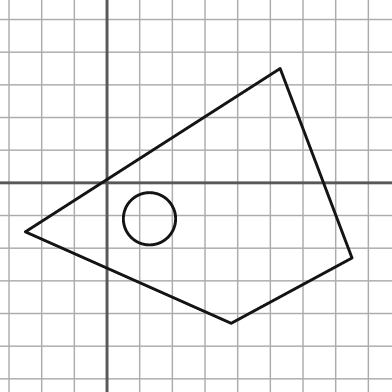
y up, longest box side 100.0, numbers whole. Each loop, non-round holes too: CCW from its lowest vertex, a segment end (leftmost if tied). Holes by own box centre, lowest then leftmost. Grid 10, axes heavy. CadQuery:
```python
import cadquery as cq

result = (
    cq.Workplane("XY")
    .moveTo(38.0, -43.0)
    .lineTo(75.0, -23.0)
    .lineTo(53.0, 35.0)
    .lineTo(-25.0, -15.0)
    .close()
    .moveTo(13.0, -11.0)
    .circle(8.0)
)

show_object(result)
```